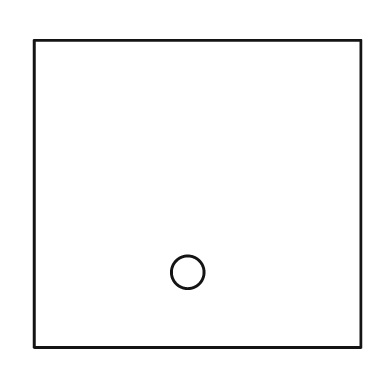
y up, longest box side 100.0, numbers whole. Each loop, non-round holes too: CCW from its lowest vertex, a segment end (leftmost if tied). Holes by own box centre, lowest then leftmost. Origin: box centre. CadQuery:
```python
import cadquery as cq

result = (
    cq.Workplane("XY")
    .moveTo(-50.0, -47.0)
    .lineTo(50.0, -47.0)
    .lineTo(50.0, 47.0)
    .lineTo(-50.0, 47.0)
    .close()
    .moveTo(-3.0, -24.0)
    .circle(5.0)
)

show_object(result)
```